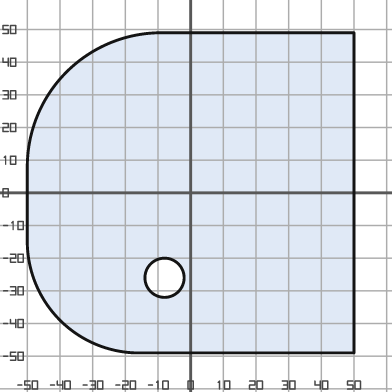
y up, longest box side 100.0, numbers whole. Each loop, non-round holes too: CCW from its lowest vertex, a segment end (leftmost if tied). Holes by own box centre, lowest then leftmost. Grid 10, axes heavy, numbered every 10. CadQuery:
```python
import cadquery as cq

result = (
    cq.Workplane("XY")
    .moveTo(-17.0, -49.0)
    .lineTo(50.0, -49.0)
    .lineTo(50.0, 49.0)
    .lineTo(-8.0, 49.0)
    .threePointArc((-38.0, 37.0), (-50.0, 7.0))
    .lineTo(-50.0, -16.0)
    .threePointArc((-40.0, -39.0), (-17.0, -49.0))
    .close()
    .moveTo(-8.0, -26.0)
    .circle(6.0)
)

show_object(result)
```